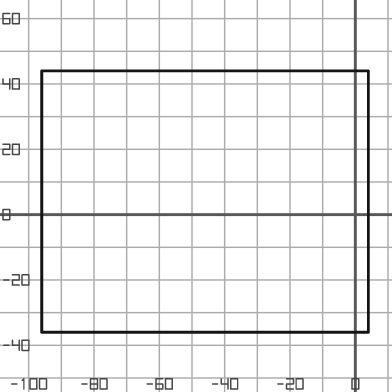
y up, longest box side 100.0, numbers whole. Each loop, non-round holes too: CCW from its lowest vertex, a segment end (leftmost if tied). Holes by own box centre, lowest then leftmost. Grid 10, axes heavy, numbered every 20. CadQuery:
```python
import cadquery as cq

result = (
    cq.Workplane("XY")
    .moveTo(-96.0, -36.0)
    .lineTo(4.0, -36.0)
    .lineTo(4.0, 44.0)
    .lineTo(-96.0, 44.0)
    .close()
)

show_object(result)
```